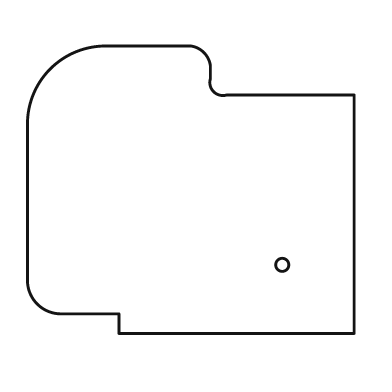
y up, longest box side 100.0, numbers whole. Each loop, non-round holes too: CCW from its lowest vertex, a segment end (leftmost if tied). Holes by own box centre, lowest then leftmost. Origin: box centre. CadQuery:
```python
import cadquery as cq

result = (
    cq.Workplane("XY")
    .moveTo(-22.0, -44.0)
    .lineTo(50.0, -44.0)
    .lineTo(50.0, 29.0)
    .lineTo(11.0, 29.0)
    .threePointArc((7.0, 30.0), (6.0, 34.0))
    .lineTo(6.0, 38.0)
    .threePointArc((4.0, 42.0), (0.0, 44.0))
    .lineTo(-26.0, 44.0)
    .threePointArc((-43.0, 37.0), (-50.0, 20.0))
    .lineTo(-50.0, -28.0)
    .threePointArc((-47.0, -35.0), (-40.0, -38.0))
    .lineTo(-22.0, -38.0)
    .close()
    .moveTo(28.0, -23.0)
    .circle(2.0)
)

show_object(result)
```